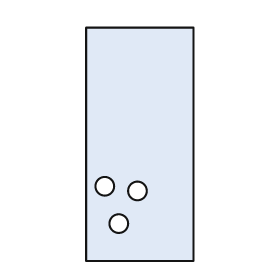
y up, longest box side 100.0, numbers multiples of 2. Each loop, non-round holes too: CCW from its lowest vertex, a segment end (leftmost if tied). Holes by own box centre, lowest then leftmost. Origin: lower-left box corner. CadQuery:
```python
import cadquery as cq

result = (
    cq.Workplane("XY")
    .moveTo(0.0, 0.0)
    .lineTo(46.0, 0.0)
    .lineTo(46.0, 100.0)
    .lineTo(0.0, 100.0)
    .close()
    .moveTo(14.0, 16.0)
    .circle(4.0)
    .moveTo(22.0, 30.0)
    .circle(4.0)
    .moveTo(8.0, 32.0)
    .circle(4.0)
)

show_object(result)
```